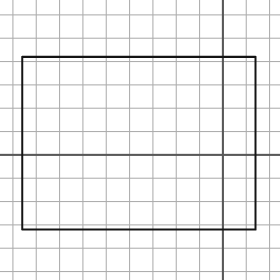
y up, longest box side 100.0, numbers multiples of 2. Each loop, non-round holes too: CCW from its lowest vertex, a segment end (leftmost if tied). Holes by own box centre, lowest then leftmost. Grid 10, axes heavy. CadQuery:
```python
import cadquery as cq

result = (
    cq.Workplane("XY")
    .moveTo(-86.0, -32.0)
    .lineTo(14.0, -32.0)
    .lineTo(14.0, 42.0)
    .lineTo(-86.0, 42.0)
    .close()
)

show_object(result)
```